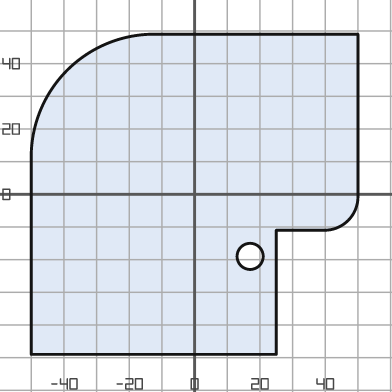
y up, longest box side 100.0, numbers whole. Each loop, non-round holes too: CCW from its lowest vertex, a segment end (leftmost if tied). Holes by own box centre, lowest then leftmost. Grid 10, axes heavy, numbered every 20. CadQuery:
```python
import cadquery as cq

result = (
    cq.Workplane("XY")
    .moveTo(-50.0, -49.0)
    .lineTo(25.0, -49.0)
    .lineTo(25.0, -11.0)
    .lineTo(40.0, -11.0)
    .threePointArc((47.0, -8.0), (50.0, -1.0))
    .lineTo(50.0, 49.0)
    .lineTo(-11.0, 49.0)
    .threePointArc((-39.0, 38.0), (-50.0, 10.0))
    .close()
    .moveTo(17.0, -19.0)
    .circle(4.0)
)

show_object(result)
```